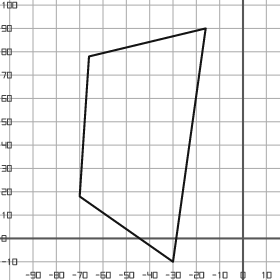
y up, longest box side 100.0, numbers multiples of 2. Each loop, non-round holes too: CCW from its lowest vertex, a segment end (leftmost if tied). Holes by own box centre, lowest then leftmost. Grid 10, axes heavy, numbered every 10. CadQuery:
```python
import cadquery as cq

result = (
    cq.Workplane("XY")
    .moveTo(-30.0, -10.0)
    .lineTo(-16.0, 90.0)
    .lineTo(-66.0, 78.0)
    .lineTo(-70.0, 18.0)
    .close()
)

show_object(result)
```